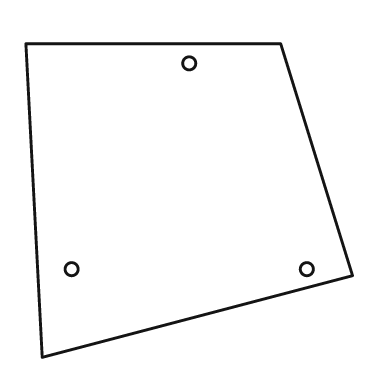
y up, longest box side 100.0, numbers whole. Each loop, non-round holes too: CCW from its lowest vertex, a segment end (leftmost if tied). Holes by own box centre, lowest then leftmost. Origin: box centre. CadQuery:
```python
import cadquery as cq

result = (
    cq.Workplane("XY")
    .moveTo(-45.0, -48.0)
    .lineTo(50.0, -23.0)
    .lineTo(28.0, 48.0)
    .lineTo(-50.0, 48.0)
    .close()
    .moveTo(-36.0, -21.0)
    .circle(2.0)
    .moveTo(36.0, -21.0)
    .circle(2.0)
    .moveTo(0.0, 42.0)
    .circle(2.0)
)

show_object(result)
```